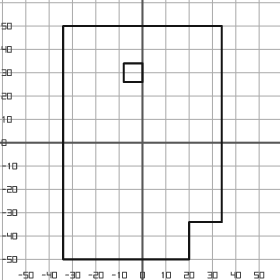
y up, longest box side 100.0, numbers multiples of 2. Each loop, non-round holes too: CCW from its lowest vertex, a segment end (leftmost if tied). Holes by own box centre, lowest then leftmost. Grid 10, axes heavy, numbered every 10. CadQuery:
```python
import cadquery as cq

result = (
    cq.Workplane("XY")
    .moveTo(-34.0, -50.0)
    .lineTo(20.0, -50.0)
    .lineTo(20.0, -34.0)
    .lineTo(34.0, -34.0)
    .lineTo(34.0, 50.0)
    .lineTo(-34.0, 50.0)
    .close()
    .moveTo(-8.0, 26.0)
    .lineTo(0.0, 26.0)
    .lineTo(0.0, 34.0)
    .lineTo(-8.0, 34.0)
    .close()
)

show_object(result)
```